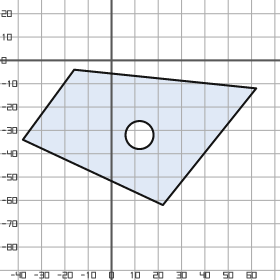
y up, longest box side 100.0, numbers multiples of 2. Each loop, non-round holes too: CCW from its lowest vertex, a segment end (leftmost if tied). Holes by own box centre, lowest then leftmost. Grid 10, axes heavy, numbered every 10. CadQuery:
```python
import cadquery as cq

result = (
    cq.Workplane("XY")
    .moveTo(22.0, -62.0)
    .lineTo(62.0, -12.0)
    .lineTo(-16.0, -4.0)
    .lineTo(-38.0, -34.0)
    .close()
    .moveTo(12.0, -32.0)
    .circle(6.0)
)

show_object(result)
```